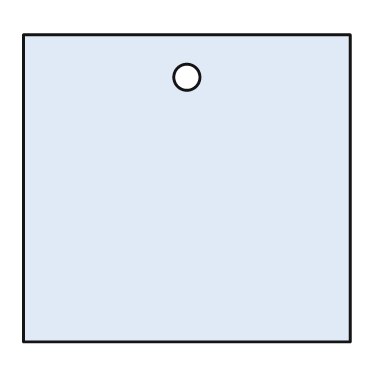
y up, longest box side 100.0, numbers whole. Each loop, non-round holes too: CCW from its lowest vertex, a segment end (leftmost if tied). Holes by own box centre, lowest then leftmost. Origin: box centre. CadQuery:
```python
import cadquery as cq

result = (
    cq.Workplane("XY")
    .moveTo(-50.0, -47.0)
    .lineTo(50.0, -47.0)
    .lineTo(50.0, 47.0)
    .lineTo(-50.0, 47.0)
    .close()
    .moveTo(0.0, 34.0)
    .circle(4.0)
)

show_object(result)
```